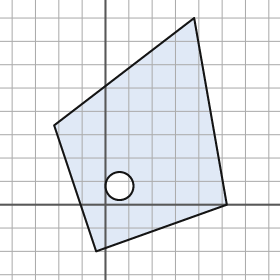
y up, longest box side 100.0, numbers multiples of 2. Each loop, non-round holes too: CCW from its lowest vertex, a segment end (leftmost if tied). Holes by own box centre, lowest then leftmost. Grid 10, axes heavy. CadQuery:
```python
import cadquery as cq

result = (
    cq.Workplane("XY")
    .moveTo(-4.0, -20.0)
    .lineTo(52.0, 0.0)
    .lineTo(38.0, 80.0)
    .lineTo(-22.0, 34.0)
    .close()
    .moveTo(6.0, 8.0)
    .circle(6.0)
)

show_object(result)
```